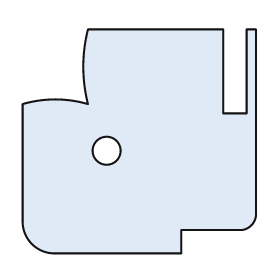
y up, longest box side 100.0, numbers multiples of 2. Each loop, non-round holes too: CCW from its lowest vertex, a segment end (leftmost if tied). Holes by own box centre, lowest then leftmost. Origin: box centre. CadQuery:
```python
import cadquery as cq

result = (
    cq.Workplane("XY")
    .moveTo(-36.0, -48.0)
    .lineTo(18.0, -48.0)
    .lineTo(18.0, -38.0)
    .lineTo(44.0, -38.0)
    .threePointArc((48.0, -36.0), (50.0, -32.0))
    .lineTo(50.0, 48.0)
    .lineTo(46.0, 48.0)
    .lineTo(46.0, 12.0)
    .lineTo(36.0, 12.0)
    .lineTo(36.0, 48.0)
    .lineTo(-22.0, 48.0)
    .threePointArc((-24.0, 32.0), (-22.0, 16.0))
    .threePointArc((-36.0, 18.0), (-50.0, 16.0))
    .lineTo(-50.0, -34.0)
    .threePointArc((-46.0, -44.0), (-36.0, -48.0))
    .close()
    .moveTo(-14.0, -4.0)
    .circle(6.0)
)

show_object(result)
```